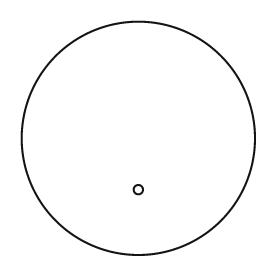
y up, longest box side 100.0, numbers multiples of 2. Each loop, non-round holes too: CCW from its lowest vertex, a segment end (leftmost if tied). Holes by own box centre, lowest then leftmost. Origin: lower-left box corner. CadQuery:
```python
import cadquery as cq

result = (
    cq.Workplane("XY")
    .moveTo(50.0, 50.0)
    .circle(50.0)
    .moveTo(50.0, 28.0)
    .circle(2.0)
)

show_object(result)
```